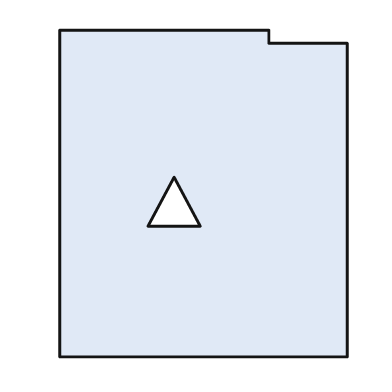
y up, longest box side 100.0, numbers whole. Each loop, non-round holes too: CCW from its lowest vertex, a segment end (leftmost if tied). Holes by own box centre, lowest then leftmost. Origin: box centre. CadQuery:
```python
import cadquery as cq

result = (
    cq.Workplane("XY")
    .moveTo(-44.0, -50.0)
    .lineTo(44.0, -50.0)
    .lineTo(44.0, 46.0)
    .lineTo(20.0, 46.0)
    .lineTo(20.0, 50.0)
    .lineTo(-44.0, 50.0)
    .close()
    .moveTo(-17.0, -10.0)
    .lineTo(-1.0, -10.0)
    .lineTo(-9.0, 5.0)
    .close()
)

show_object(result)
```